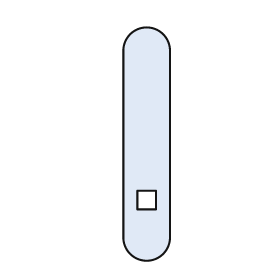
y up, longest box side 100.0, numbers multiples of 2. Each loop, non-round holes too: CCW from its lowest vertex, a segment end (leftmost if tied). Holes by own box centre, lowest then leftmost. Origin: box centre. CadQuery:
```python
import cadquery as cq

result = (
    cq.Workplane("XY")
    .moveTo(-10.0, -40.0)
    .threePointArc((0.0, -50.0), (10.0, -40.0))
    .lineTo(10.0, 40.0)
    .threePointArc((0.0, 50.0), (-10.0, 40.0))
    .close()
    .moveTo(-4.0, -28.0)
    .lineTo(4.0, -28.0)
    .lineTo(4.0, -20.0)
    .lineTo(-4.0, -20.0)
    .close()
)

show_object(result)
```